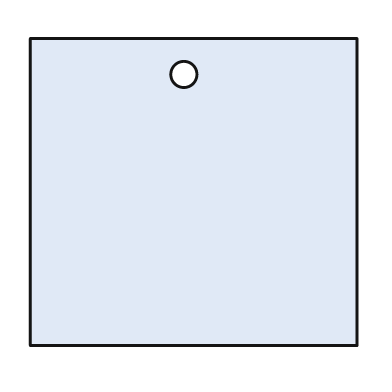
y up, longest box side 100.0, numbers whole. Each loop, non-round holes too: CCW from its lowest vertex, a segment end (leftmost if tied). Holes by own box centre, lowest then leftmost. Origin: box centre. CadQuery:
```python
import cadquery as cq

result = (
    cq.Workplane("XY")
    .moveTo(-50.0, -47.0)
    .lineTo(50.0, -47.0)
    .lineTo(50.0, 47.0)
    .lineTo(-50.0, 47.0)
    .close()
    .moveTo(-3.0, 36.0)
    .circle(4.0)
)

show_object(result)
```